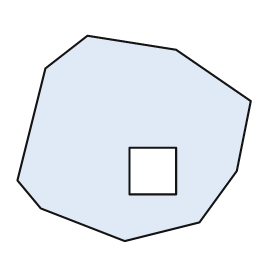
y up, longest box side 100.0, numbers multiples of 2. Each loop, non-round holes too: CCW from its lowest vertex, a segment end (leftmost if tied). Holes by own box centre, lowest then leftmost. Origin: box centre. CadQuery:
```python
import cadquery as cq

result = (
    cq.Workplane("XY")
    .moveTo(-4.0, -44.0)
    .lineTo(28.0, -36.0)
    .lineTo(44.0, -14.0)
    .lineTo(50.0, 16.0)
    .lineTo(18.0, 38.0)
    .lineTo(-20.0, 44.0)
    .lineTo(-38.0, 30.0)
    .lineTo(-50.0, -18.0)
    .lineTo(-40.0, -30.0)
    .close()
    .moveTo(-2.0, -24.0)
    .lineTo(18.0, -24.0)
    .lineTo(18.0, -4.0)
    .lineTo(-2.0, -4.0)
    .close()
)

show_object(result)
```